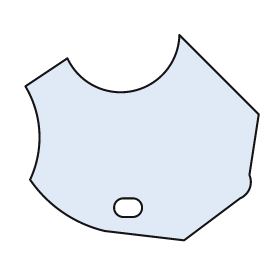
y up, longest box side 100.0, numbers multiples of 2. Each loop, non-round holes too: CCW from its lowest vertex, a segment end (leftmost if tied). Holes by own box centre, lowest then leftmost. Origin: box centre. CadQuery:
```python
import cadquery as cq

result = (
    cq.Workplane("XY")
    .moveTo(18.0, -44.0)
    .lineTo(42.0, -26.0)
    .threePointArc((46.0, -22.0), (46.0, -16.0))
    .lineTo(50.0, 10.0)
    .lineTo(16.0, 44.0)
    .threePointArc((-4.0, 20.0), (-32.0, 34.0))
    .lineTo(-50.0, 22.0)
    .threePointArc((-44.0, 2.0), (-48.0, -18.0))
    .threePointArc((-34.0, -32.0), (-16.0, -40.0))
    .close()
    .moveTo(-8.0, -34.0)
    .lineTo(-4.0, -34.0)
    .threePointArc((0.0, -30.0), (-4.0, -26.0))
    .lineTo(-8.0, -26.0)
    .threePointArc((-12.0, -30.0), (-8.0, -34.0))
    .close()
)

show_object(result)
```